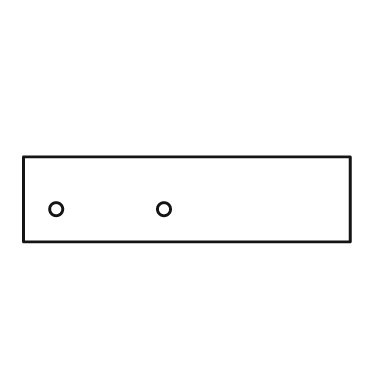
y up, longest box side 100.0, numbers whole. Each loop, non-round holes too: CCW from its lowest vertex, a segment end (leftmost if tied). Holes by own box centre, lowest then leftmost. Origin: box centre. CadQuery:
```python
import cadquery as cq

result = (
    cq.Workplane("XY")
    .moveTo(-50.0, -13.0)
    .lineTo(50.0, -13.0)
    .lineTo(50.0, 13.0)
    .lineTo(-50.0, 13.0)
    .close()
    .moveTo(-40.0, -3.0)
    .circle(2.0)
    .moveTo(-7.0, -3.0)
    .circle(2.0)
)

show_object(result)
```